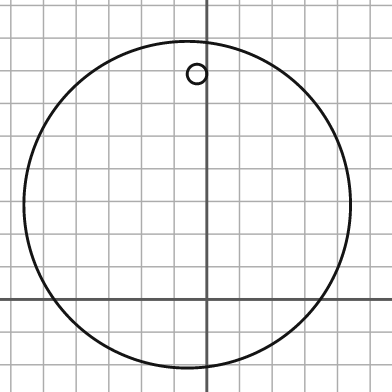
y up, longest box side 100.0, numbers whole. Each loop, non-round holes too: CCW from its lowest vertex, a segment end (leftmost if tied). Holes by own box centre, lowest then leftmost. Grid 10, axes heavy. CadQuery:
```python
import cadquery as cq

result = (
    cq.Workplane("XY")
    .moveTo(-6.0, 29.0)
    .circle(50.0)
    .moveTo(-3.0, 69.0)
    .circle(3.0)
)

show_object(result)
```